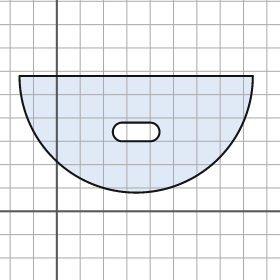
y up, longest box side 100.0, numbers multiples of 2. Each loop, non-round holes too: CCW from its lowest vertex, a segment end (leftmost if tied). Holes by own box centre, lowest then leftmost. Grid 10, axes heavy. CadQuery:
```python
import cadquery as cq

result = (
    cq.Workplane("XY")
    .moveTo(-16.0, 58.0)
    .threePointArc((34.0, 8.0), (84.0, 58.0))
    .close()
    .moveTo(28.0, 30.0)
    .lineTo(40.0, 30.0)
    .threePointArc((44.0, 34.0), (40.0, 38.0))
    .lineTo(28.0, 38.0)
    .threePointArc((24.0, 34.0), (28.0, 30.0))
    .close()
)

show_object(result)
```